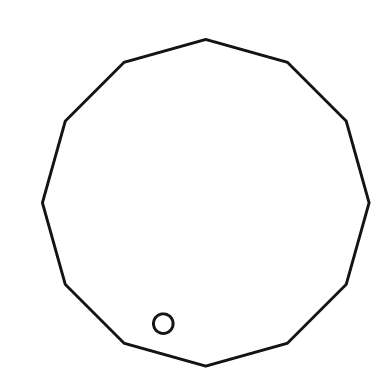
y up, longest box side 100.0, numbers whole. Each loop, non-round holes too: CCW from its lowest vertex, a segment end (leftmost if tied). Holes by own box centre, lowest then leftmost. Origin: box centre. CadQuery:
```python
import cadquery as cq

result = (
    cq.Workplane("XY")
    .moveTo(0.0, -50.0)
    .lineTo(25.0, -43.0)
    .lineTo(43.0, -25.0)
    .lineTo(50.0, 0.0)
    .lineTo(43.0, 25.0)
    .lineTo(25.0, 43.0)
    .lineTo(0.0, 50.0)
    .lineTo(-25.0, 43.0)
    .lineTo(-43.0, 25.0)
    .lineTo(-50.0, 0.0)
    .lineTo(-43.0, -25.0)
    .lineTo(-25.0, -43.0)
    .close()
    .moveTo(-13.0, -37.0)
    .circle(3.0)
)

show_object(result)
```